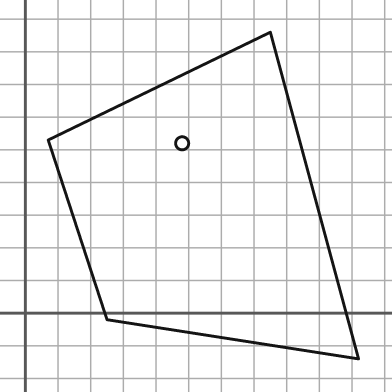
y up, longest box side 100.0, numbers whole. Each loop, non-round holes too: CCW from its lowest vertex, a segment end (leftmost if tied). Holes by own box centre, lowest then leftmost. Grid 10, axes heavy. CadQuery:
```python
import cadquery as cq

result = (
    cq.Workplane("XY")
    .moveTo(102.0, -14.0)
    .lineTo(75.0, 86.0)
    .lineTo(7.0, 53.0)
    .lineTo(25.0, -2.0)
    .close()
    .moveTo(48.0, 52.0)
    .circle(2.0)
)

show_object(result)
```